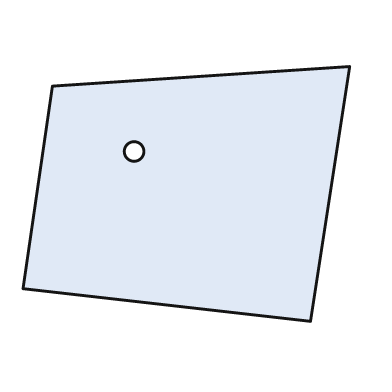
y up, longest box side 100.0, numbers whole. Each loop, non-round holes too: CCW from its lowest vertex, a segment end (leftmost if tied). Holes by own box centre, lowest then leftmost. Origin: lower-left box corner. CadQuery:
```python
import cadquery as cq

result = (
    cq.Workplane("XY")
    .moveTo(88.0, 0.0)
    .lineTo(100.0, 78.0)
    .lineTo(9.0, 72.0)
    .lineTo(0.0, 10.0)
    .close()
    .moveTo(34.0, 52.0)
    .circle(3.0)
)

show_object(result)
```